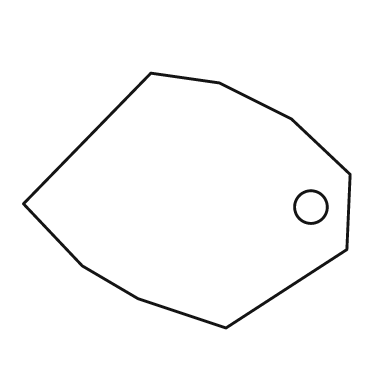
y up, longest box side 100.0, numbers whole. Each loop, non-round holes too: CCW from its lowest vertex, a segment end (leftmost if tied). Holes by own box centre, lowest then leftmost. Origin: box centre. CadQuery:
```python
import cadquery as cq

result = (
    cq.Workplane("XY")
    .moveTo(12.0, -39.0)
    .lineTo(49.0, -15.0)
    .lineTo(50.0, 8.0)
    .lineTo(32.0, 25.0)
    .lineTo(10.0, 36.0)
    .lineTo(-11.0, 39.0)
    .lineTo(-50.0, -1.0)
    .lineTo(-32.0, -20.0)
    .lineTo(-15.0, -30.0)
    .close()
    .moveTo(38.0, -2.0)
    .circle(5.0)
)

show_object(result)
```